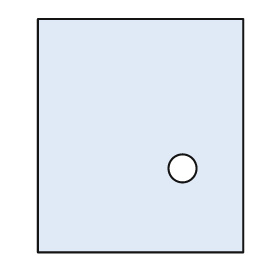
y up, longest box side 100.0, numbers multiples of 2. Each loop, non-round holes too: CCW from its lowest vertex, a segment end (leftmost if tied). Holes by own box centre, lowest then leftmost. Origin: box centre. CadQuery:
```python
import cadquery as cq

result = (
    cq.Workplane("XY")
    .moveTo(-44.0, -50.0)
    .lineTo(44.0, -50.0)
    .lineTo(44.0, 50.0)
    .lineTo(-44.0, 50.0)
    .close()
    .moveTo(18.0, -14.0)
    .circle(6.0)
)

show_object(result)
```